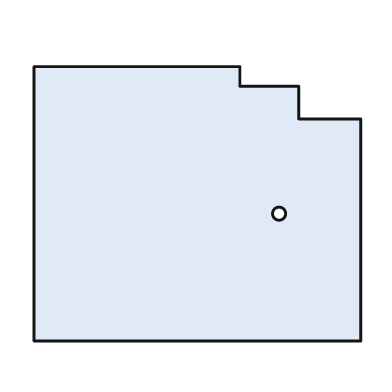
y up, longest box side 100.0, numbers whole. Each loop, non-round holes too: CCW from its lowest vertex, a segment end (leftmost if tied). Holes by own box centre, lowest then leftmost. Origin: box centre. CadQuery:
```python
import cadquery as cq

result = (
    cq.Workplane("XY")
    .moveTo(-50.0, -42.0)
    .lineTo(50.0, -42.0)
    .lineTo(50.0, 26.0)
    .lineTo(31.0, 26.0)
    .lineTo(31.0, 36.0)
    .lineTo(13.0, 36.0)
    .lineTo(13.0, 42.0)
    .lineTo(-50.0, 42.0)
    .close()
    .moveTo(25.0, -3.0)
    .circle(2.0)
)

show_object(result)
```